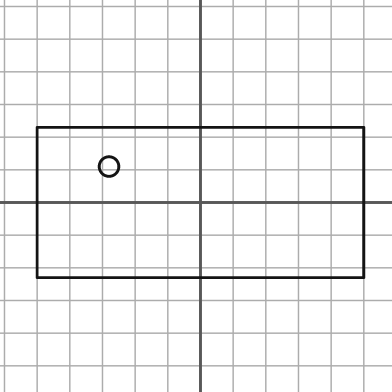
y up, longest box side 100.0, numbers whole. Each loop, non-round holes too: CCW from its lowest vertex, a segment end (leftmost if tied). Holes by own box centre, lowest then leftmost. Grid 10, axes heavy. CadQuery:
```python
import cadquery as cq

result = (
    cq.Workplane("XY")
    .moveTo(-50.0, -23.0)
    .lineTo(50.0, -23.0)
    .lineTo(50.0, 23.0)
    .lineTo(-50.0, 23.0)
    .close()
    .moveTo(-28.0, 11.0)
    .circle(3.0)
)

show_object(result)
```